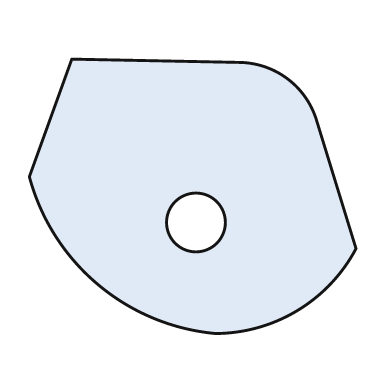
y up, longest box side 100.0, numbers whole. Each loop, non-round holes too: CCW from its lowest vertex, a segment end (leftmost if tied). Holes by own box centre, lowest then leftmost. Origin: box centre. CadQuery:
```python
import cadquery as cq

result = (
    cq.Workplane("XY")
    .moveTo(7.0, -42.0)
    .threePointArc((32.0, -35.0), (50.0, -16.0))
    .lineTo(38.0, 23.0)
    .threePointArc((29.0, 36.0), (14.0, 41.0))
    .lineTo(-37.0, 42.0)
    .lineTo(-50.0, 6.0)
    .threePointArc((-29.0, -27.0), (7.0, -42.0))
    .close()
    .moveTo(1.0, -8.0)
    .circle(9.0)
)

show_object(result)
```